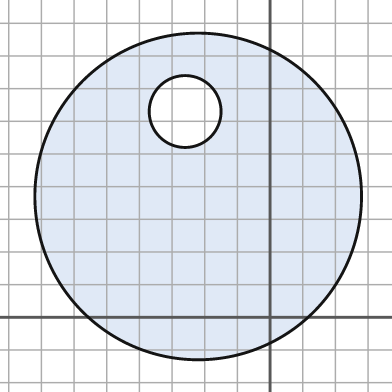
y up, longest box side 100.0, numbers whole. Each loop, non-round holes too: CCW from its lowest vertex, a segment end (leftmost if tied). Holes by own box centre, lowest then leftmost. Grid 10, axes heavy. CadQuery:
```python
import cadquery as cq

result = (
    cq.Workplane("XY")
    .moveTo(-22.0, 37.0)
    .circle(50.0)
    .moveTo(-26.0, 63.0)
    .circle(11.0)
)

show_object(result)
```